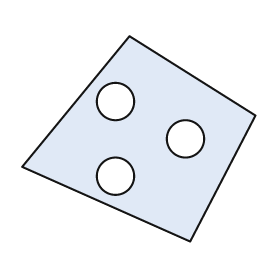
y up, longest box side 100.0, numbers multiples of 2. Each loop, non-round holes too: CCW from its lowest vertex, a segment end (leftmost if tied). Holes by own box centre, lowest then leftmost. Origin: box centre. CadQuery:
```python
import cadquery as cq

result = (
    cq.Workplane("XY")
    .moveTo(22.0, -44.0)
    .lineTo(50.0, 10.0)
    .lineTo(-4.0, 44.0)
    .lineTo(-50.0, -12.0)
    .close()
    .moveTo(-10.0, -16.0)
    .circle(8.0)
    .moveTo(20.0, 0.0)
    .circle(8.0)
    .moveTo(-10.0, 16.0)
    .circle(8.0)
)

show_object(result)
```